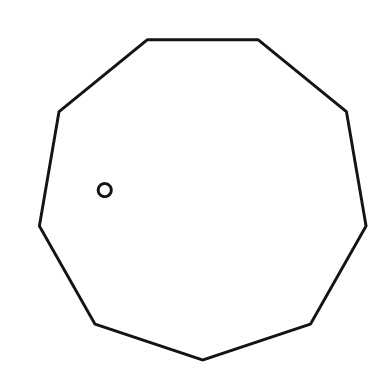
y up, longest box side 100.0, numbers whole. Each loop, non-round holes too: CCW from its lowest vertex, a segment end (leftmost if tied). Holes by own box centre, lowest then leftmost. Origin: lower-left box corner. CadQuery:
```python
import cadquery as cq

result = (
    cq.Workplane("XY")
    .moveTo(50.0, 0.0)
    .lineTo(83.0, 11.0)
    .lineTo(100.0, 41.0)
    .lineTo(94.0, 76.0)
    .lineTo(67.0, 98.0)
    .lineTo(33.0, 98.0)
    .lineTo(6.0, 76.0)
    .lineTo(0.0, 41.0)
    .lineTo(17.0, 11.0)
    .close()
    .moveTo(20.0, 52.0)
    .circle(2.0)
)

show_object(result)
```